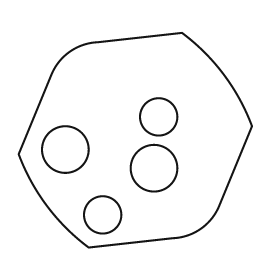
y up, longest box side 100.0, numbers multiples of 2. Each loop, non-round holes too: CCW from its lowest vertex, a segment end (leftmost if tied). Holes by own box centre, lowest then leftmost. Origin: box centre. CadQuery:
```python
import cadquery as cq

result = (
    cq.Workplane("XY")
    .moveTo(-20.0, -46.0)
    .lineTo(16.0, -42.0)
    .threePointArc((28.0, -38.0), (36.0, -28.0))
    .lineTo(50.0, 6.0)
    .threePointArc((38.0, 28.0), (20.0, 46.0))
    .lineTo(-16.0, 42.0)
    .threePointArc((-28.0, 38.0), (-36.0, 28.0))
    .lineTo(-50.0, -6.0)
    .threePointArc((-38.0, -28.0), (-20.0, -46.0))
    .close()
    .moveTo(-14.0, -32.0)
    .circle(8.0)
    .moveTo(8.0, -12.0)
    .circle(10.0)
    .moveTo(-30.0, -4.0)
    .circle(10.0)
    .moveTo(10.0, 10.0)
    .circle(8.0)
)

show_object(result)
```